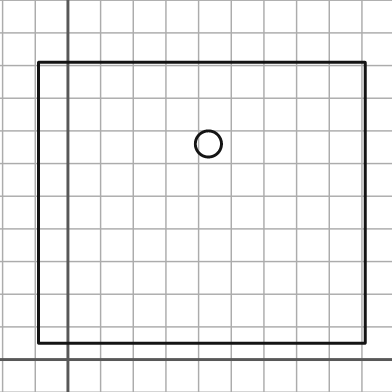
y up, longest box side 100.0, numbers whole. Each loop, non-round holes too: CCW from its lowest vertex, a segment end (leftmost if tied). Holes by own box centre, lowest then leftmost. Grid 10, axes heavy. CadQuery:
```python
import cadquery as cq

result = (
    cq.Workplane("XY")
    .moveTo(-9.0, 5.0)
    .lineTo(91.0, 5.0)
    .lineTo(91.0, 91.0)
    .lineTo(-9.0, 91.0)
    .close()
    .moveTo(43.0, 66.0)
    .circle(4.0)
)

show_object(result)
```